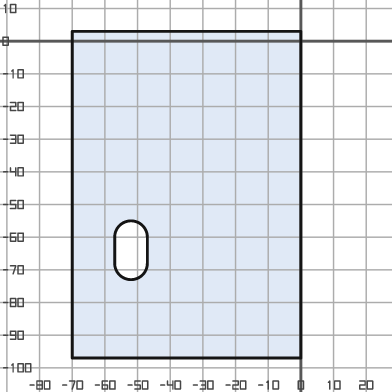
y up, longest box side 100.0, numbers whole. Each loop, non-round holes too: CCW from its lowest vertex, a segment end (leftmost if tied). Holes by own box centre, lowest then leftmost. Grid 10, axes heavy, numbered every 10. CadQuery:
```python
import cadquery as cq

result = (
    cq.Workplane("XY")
    .moveTo(-70.0, -97.0)
    .lineTo(0.0, -97.0)
    .lineTo(0.0, 3.0)
    .lineTo(-70.0, 3.0)
    .close()
    .moveTo(-57.0, -68.0)
    .threePointArc((-52.0, -73.0), (-47.0, -68.0))
    .lineTo(-47.0, -60.0)
    .threePointArc((-52.0, -55.0), (-57.0, -60.0))
    .close()
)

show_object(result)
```